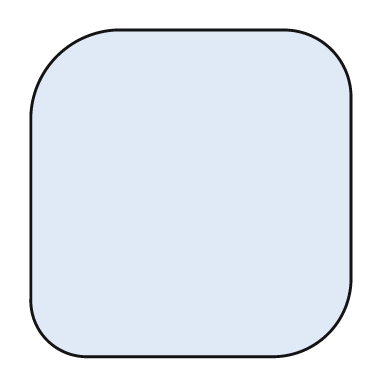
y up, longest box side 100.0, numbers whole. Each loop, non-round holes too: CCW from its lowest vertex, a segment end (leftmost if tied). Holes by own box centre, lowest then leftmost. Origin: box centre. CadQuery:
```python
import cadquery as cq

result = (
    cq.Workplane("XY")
    .moveTo(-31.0, -50.0)
    .lineTo(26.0, -50.0)
    .threePointArc((42.0, -43.0), (49.0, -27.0))
    .lineTo(49.0, 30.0)
    .threePointArc((43.0, 44.0), (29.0, 50.0))
    .lineTo(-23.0, 50.0)
    .threePointArc((-41.0, 42.0), (-49.0, 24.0))
    .lineTo(-49.0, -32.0)
    .threePointArc((-44.0, -45.0), (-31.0, -50.0))
    .close()
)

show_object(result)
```